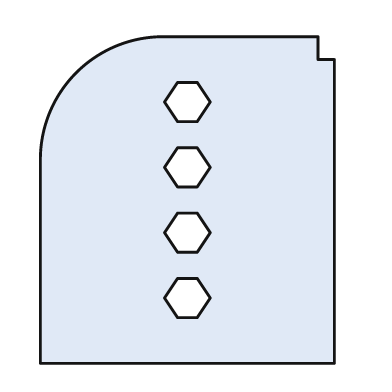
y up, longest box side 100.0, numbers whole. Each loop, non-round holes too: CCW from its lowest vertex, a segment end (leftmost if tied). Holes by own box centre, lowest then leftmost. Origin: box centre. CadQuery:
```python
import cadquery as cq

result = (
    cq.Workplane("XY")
    .moveTo(-45.0, -50.0)
    .lineTo(45.0, -50.0)
    .lineTo(45.0, 43.0)
    .lineTo(40.0, 43.0)
    .lineTo(40.0, 50.0)
    .lineTo(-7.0, 50.0)
    .threePointArc((-34.0, 39.0), (-45.0, 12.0))
    .close()
    .moveTo(-3.0, -36.0)
    .lineTo(3.0, -36.0)
    .lineTo(7.0, -30.0)
    .lineTo(3.0, -24.0)
    .lineTo(-3.0, -24.0)
    .lineTo(-7.0, -30.0)
    .close()
    .moveTo(-3.0, -16.0)
    .lineTo(3.0, -16.0)
    .lineTo(7.0, -10.0)
    .lineTo(3.0, -4.0)
    .lineTo(-3.0, -4.0)
    .lineTo(-7.0, -10.0)
    .close()
    .moveTo(-3.0, 4.0)
    .lineTo(3.0, 4.0)
    .lineTo(7.0, 10.0)
    .lineTo(3.0, 16.0)
    .lineTo(-3.0, 16.0)
    .lineTo(-7.0, 10.0)
    .close()
    .moveTo(-3.0, 24.0)
    .lineTo(3.0, 24.0)
    .lineTo(7.0, 30.0)
    .lineTo(3.0, 36.0)
    .lineTo(-3.0, 36.0)
    .lineTo(-7.0, 30.0)
    .close()
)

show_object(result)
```